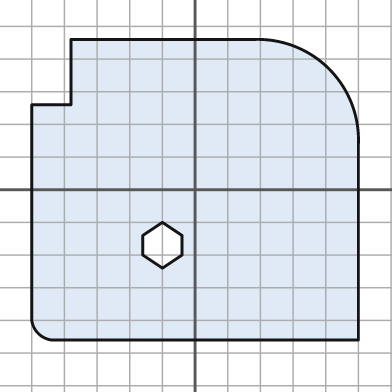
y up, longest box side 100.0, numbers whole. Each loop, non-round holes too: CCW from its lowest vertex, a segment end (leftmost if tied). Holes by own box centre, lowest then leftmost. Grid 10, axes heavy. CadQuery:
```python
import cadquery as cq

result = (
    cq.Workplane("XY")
    .moveTo(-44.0, -46.0)
    .lineTo(50.0, -46.0)
    .lineTo(50.0, 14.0)
    .threePointArc((41.0, 37.0), (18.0, 46.0))
    .lineTo(-38.0, 46.0)
    .lineTo(-38.0, 26.0)
    .lineTo(-50.0, 26.0)
    .lineTo(-50.0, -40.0)
    .threePointArc((-48.0, -44.0), (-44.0, -46.0))
    .close()
    .moveTo(-10.0, -24.0)
    .lineTo(-4.0, -20.0)
    .lineTo(-4.0, -14.0)
    .lineTo(-10.0, -10.0)
    .lineTo(-16.0, -14.0)
    .lineTo(-16.0, -20.0)
    .close()
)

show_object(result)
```